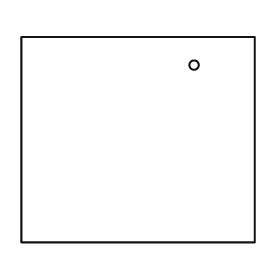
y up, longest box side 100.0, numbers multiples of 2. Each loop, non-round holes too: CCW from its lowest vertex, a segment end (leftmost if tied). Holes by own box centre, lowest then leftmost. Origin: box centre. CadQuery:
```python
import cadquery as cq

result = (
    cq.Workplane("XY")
    .moveTo(-50.0, -44.0)
    .lineTo(50.0, -44.0)
    .lineTo(50.0, 44.0)
    .lineTo(-50.0, 44.0)
    .close()
    .moveTo(24.0, 32.0)
    .circle(2.0)
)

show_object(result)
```